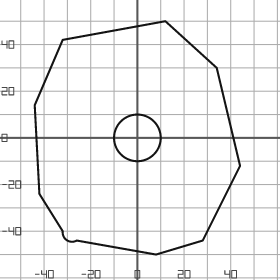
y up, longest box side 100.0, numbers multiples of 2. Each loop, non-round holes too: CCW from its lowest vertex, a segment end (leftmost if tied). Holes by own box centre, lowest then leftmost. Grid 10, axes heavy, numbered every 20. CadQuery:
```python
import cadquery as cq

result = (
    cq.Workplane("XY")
    .moveTo(8.0, -50.0)
    .lineTo(28.0, -44.0)
    .lineTo(44.0, -12.0)
    .lineTo(34.0, 30.0)
    .lineTo(12.0, 50.0)
    .lineTo(-32.0, 42.0)
    .lineTo(-44.0, 14.0)
    .lineTo(-42.0, -24.0)
    .lineTo(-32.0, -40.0)
    .threePointArc((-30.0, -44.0), (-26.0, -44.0))
    .close()
    .moveTo(0.0, 0.0)
    .circle(10.0)
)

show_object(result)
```